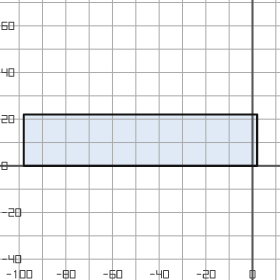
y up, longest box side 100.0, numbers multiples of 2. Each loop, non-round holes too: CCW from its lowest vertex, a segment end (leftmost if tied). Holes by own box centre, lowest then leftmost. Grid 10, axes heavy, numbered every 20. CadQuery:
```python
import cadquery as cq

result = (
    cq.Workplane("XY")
    .moveTo(-98.0, 0.0)
    .lineTo(2.0, 0.0)
    .lineTo(2.0, 22.0)
    .lineTo(-98.0, 22.0)
    .close()
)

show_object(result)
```